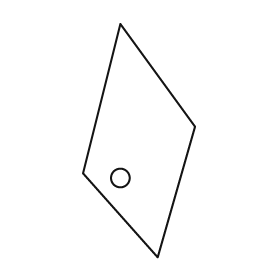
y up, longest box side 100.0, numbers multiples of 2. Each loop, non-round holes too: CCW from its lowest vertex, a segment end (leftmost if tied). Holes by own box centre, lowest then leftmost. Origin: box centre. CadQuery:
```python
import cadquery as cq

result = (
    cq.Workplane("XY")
    .moveTo(8.0, -50.0)
    .lineTo(24.0, 6.0)
    .lineTo(-8.0, 50.0)
    .lineTo(-24.0, -14.0)
    .close()
    .moveTo(-8.0, -16.0)
    .circle(4.0)
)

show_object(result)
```